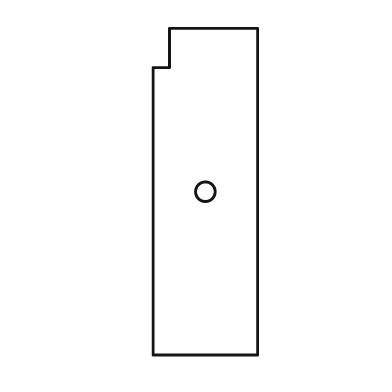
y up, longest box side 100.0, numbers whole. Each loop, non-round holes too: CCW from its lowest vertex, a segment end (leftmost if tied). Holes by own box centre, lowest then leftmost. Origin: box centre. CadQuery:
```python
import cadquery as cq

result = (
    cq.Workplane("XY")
    .moveTo(-16.0, -50.0)
    .lineTo(16.0, -50.0)
    .lineTo(16.0, 50.0)
    .lineTo(-11.0, 50.0)
    .lineTo(-11.0, 38.0)
    .lineTo(-16.0, 38.0)
    .close()
    .moveTo(0.0, 0.0)
    .circle(3.0)
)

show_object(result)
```